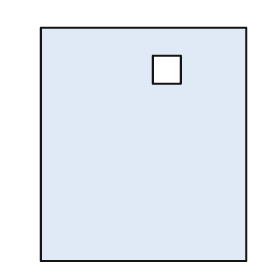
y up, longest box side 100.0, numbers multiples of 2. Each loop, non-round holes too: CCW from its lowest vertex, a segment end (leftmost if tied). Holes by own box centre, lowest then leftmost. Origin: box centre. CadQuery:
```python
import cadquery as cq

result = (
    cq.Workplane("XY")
    .moveTo(-44.0, -50.0)
    .lineTo(44.0, -50.0)
    .lineTo(44.0, 50.0)
    .lineTo(-44.0, 50.0)
    .close()
    .moveTo(4.0, 26.0)
    .lineTo(16.0, 26.0)
    .lineTo(16.0, 38.0)
    .lineTo(4.0, 38.0)
    .close()
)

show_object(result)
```